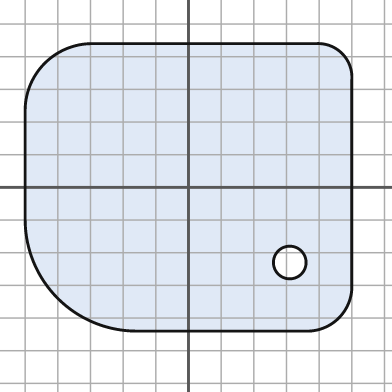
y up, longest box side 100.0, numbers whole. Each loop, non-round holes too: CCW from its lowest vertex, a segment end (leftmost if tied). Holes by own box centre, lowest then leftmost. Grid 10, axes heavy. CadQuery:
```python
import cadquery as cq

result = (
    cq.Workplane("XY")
    .moveTo(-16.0, -44.0)
    .lineTo(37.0, -44.0)
    .threePointArc((46.0, -40.0), (50.0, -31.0))
    .lineTo(50.0, 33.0)
    .threePointArc((47.0, 41.0), (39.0, 44.0))
    .lineTo(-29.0, 44.0)
    .threePointArc((-44.0, 38.0), (-50.0, 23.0))
    .lineTo(-50.0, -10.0)
    .threePointArc((-40.0, -34.0), (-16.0, -44.0))
    .close()
    .moveTo(31.0, -23.0)
    .circle(5.0)
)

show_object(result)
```